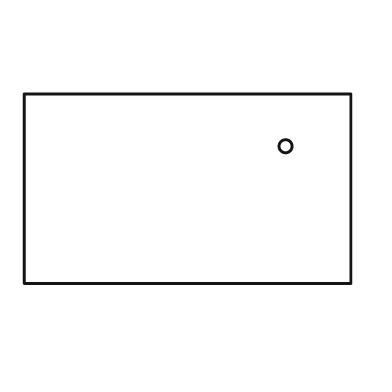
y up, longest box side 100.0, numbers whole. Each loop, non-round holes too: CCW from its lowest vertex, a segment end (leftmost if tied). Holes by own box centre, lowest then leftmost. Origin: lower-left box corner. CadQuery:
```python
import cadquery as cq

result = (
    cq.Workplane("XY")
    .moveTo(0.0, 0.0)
    .lineTo(100.0, 0.0)
    .lineTo(100.0, 58.0)
    .lineTo(0.0, 58.0)
    .close()
    .moveTo(80.0, 42.0)
    .circle(2.0)
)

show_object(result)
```